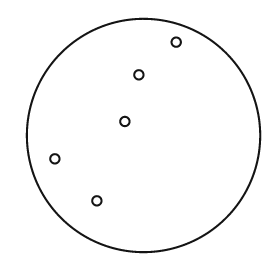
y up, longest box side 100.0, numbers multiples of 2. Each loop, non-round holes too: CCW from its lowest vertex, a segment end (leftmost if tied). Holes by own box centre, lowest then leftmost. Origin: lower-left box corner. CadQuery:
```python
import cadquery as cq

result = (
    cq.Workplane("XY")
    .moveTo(50.0, 50.0)
    .circle(50.0)
    .moveTo(30.0, 22.0)
    .circle(2.0)
    .moveTo(12.0, 40.0)
    .circle(2.0)
    .moveTo(42.0, 56.0)
    .circle(2.0)
    .moveTo(48.0, 76.0)
    .circle(2.0)
    .moveTo(64.0, 90.0)
    .circle(2.0)
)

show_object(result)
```